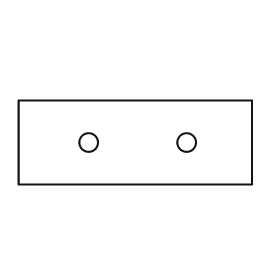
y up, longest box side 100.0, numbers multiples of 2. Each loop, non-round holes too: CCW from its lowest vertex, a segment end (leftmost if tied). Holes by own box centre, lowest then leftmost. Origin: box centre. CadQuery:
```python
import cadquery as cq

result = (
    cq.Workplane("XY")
    .moveTo(-50.0, -18.0)
    .lineTo(50.0, -18.0)
    .lineTo(50.0, 18.0)
    .lineTo(-50.0, 18.0)
    .close()
    .moveTo(-20.0, 0.0)
    .circle(4.0)
    .moveTo(22.0, 0.0)
    .circle(4.0)
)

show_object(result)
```